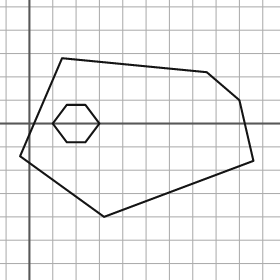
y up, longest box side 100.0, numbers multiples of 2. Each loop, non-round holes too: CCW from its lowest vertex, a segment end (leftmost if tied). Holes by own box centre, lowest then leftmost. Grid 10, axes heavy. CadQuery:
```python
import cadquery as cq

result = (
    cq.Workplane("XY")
    .moveTo(32.0, -40.0)
    .lineTo(96.0, -16.0)
    .lineTo(90.0, 10.0)
    .lineTo(76.0, 22.0)
    .lineTo(14.0, 28.0)
    .lineTo(-4.0, -14.0)
    .close()
    .moveTo(16.0, -8.0)
    .lineTo(24.0, -8.0)
    .lineTo(30.0, 0.0)
    .lineTo(24.0, 8.0)
    .lineTo(16.0, 8.0)
    .lineTo(10.0, 0.0)
    .close()
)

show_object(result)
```